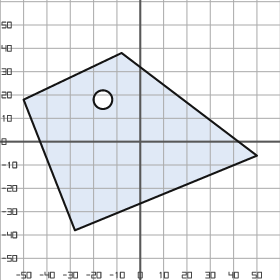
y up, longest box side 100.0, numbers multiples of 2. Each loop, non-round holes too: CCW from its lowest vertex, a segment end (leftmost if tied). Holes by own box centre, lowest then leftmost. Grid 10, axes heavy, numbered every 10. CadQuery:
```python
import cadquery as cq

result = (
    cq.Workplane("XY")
    .moveTo(-28.0, -38.0)
    .lineTo(50.0, -6.0)
    .lineTo(-8.0, 38.0)
    .lineTo(-50.0, 18.0)
    .close()
    .moveTo(-16.0, 18.0)
    .circle(4.0)
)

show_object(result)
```